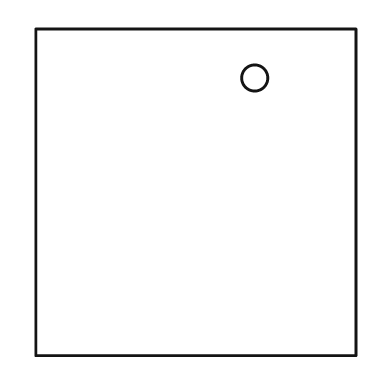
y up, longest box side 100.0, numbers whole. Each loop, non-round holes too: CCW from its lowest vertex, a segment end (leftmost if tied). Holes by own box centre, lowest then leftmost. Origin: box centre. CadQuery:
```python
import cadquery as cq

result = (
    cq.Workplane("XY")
    .moveTo(-49.0, -50.0)
    .lineTo(49.0, -50.0)
    .lineTo(49.0, 50.0)
    .lineTo(-49.0, 50.0)
    .close()
    .moveTo(18.0, 35.0)
    .circle(4.0)
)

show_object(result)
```